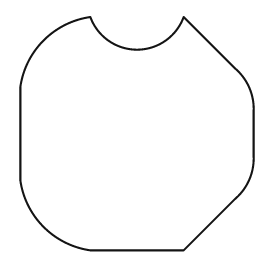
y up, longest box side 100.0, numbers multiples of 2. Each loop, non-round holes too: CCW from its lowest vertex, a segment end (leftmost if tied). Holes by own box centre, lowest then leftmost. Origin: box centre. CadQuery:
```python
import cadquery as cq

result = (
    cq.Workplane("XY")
    .moveTo(-20.0, -50.0)
    .lineTo(20.0, -50.0)
    .lineTo(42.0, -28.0)
    .threePointArc((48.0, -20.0), (50.0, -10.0))
    .lineTo(50.0, 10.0)
    .threePointArc((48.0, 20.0), (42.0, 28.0))
    .lineTo(20.0, 50.0)
    .threePointArc((0.0, 36.0), (-20.0, 50.0))
    .threePointArc((-40.0, 40.0), (-50.0, 20.0))
    .lineTo(-50.0, -20.0)
    .threePointArc((-40.0, -40.0), (-20.0, -50.0))
    .close()
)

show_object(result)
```